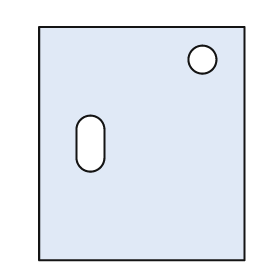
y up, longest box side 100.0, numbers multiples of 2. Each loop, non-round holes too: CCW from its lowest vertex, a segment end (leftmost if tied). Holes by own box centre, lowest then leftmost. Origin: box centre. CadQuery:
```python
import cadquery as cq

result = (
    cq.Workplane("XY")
    .moveTo(-44.0, -50.0)
    .lineTo(44.0, -50.0)
    .lineTo(44.0, 50.0)
    .lineTo(-44.0, 50.0)
    .close()
    .moveTo(-28.0, -6.0)
    .threePointArc((-22.0, -12.0), (-16.0, -6.0))
    .lineTo(-16.0, 6.0)
    .threePointArc((-22.0, 12.0), (-28.0, 6.0))
    .close()
    .moveTo(26.0, 36.0)
    .circle(6.0)
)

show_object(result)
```